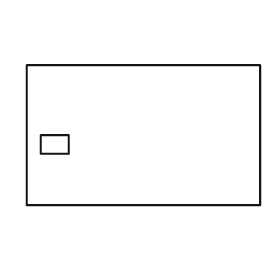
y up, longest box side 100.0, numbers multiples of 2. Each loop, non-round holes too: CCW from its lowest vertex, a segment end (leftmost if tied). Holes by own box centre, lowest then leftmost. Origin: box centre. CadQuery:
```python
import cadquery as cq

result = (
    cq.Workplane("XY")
    .moveTo(-50.0, -30.0)
    .lineTo(50.0, -30.0)
    .lineTo(50.0, 30.0)
    .lineTo(-50.0, 30.0)
    .close()
    .moveTo(-44.0, -8.0)
    .lineTo(-32.0, -8.0)
    .lineTo(-32.0, 0.0)
    .lineTo(-44.0, 0.0)
    .close()
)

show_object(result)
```